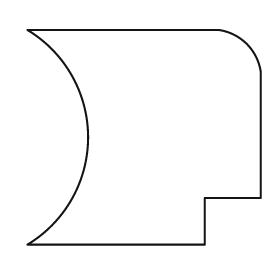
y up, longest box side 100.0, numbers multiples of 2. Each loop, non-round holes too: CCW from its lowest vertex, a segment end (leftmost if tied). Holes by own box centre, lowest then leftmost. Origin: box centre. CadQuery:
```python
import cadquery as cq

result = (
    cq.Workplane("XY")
    .moveTo(-50.0, -46.0)
    .lineTo(26.0, -46.0)
    .lineTo(26.0, -26.0)
    .lineTo(50.0, -26.0)
    .lineTo(50.0, 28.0)
    .threePointArc((44.0, 40.0), (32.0, 46.0))
    .lineTo(-50.0, 46.0)
    .threePointArc((-24.0, 0.0), (-50.0, -46.0))
    .close()
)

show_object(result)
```